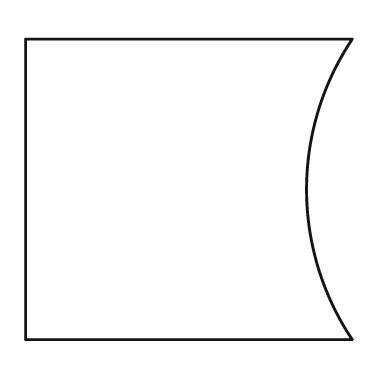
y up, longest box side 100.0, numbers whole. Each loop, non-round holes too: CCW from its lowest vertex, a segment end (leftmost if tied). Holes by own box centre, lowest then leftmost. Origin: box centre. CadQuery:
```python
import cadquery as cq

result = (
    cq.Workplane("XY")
    .moveTo(-50.0, -46.0)
    .lineTo(50.0, -46.0)
    .threePointArc((36.0, 0.0), (50.0, 46.0))
    .lineTo(-50.0, 46.0)
    .close()
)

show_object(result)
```